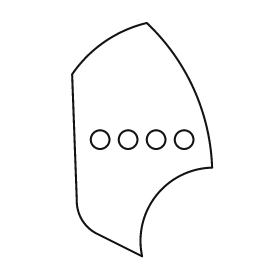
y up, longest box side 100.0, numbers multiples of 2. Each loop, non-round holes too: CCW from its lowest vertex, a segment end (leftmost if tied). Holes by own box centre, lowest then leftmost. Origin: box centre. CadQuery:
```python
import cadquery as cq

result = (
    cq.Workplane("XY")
    .moveTo(0.0, -50.0)
    .threePointArc((6.0, -24.0), (30.0, -12.0))
    .threePointArc((22.0, 22.0), (2.0, 50.0))
    .threePointArc((-16.0, 42.0), (-30.0, 28.0))
    .lineTo(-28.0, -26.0)
    .threePointArc((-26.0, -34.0), (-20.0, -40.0))
    .close()
    .moveTo(-18.0, 0.0)
    .circle(4.0)
    .moveTo(-6.0, 0.0)
    .circle(4.0)
    .moveTo(6.0, 0.0)
    .circle(4.0)
    .moveTo(18.0, 0.0)
    .circle(4.0)
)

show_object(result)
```